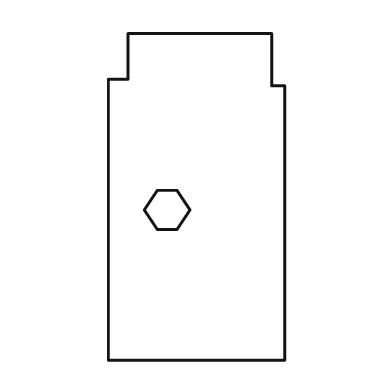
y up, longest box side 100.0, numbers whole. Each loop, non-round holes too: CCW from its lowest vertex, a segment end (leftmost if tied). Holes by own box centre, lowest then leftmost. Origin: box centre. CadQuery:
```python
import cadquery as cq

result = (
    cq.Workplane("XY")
    .moveTo(-27.0, -50.0)
    .lineTo(27.0, -50.0)
    .lineTo(27.0, 34.0)
    .lineTo(23.0, 34.0)
    .lineTo(23.0, 50.0)
    .lineTo(-21.0, 50.0)
    .lineTo(-21.0, 36.0)
    .lineTo(-27.0, 36.0)
    .close()
    .moveTo(-12.0, -10.0)
    .lineTo(-6.0, -10.0)
    .lineTo(-2.0, -4.0)
    .lineTo(-6.0, 2.0)
    .lineTo(-12.0, 2.0)
    .lineTo(-16.0, -4.0)
    .close()
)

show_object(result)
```